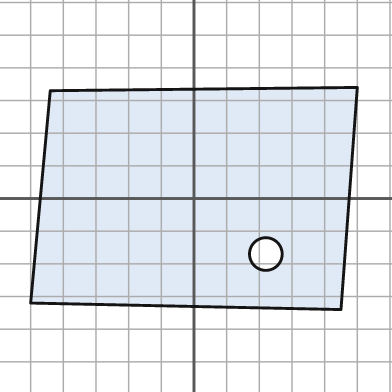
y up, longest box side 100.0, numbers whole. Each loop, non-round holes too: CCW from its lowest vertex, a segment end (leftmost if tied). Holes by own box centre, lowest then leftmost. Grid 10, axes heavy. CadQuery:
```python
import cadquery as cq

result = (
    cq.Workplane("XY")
    .moveTo(45.0, -34.0)
    .lineTo(50.0, 34.0)
    .lineTo(-44.0, 33.0)
    .lineTo(-50.0, -32.0)
    .close()
    .moveTo(22.0, -17.0)
    .circle(5.0)
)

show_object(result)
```